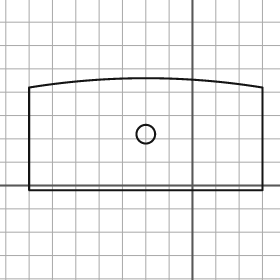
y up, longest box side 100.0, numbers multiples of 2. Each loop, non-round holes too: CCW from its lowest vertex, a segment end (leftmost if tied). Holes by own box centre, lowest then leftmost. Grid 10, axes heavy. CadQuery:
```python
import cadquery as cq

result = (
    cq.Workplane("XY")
    .moveTo(-70.0, -2.0)
    .lineTo(30.0, -2.0)
    .lineTo(30.0, 42.0)
    .threePointArc((-20.0, 46.0), (-70.0, 42.0))
    .close()
    .moveTo(-20.0, 22.0)
    .circle(4.0)
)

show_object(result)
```